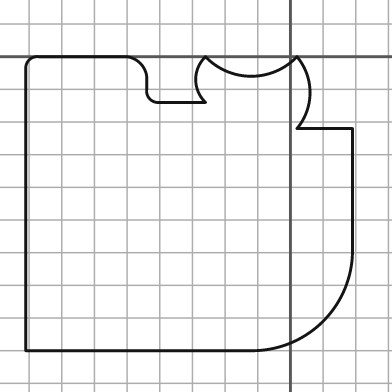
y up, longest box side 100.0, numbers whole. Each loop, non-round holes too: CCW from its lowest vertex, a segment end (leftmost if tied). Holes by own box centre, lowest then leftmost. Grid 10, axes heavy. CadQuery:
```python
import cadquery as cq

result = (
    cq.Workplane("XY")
    .moveTo(-81.0, -90.0)
    .lineTo(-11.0, -90.0)
    .threePointArc((10.0, -81.0), (19.0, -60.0))
    .lineTo(19.0, -22.0)
    .lineTo(2.0, -22.0)
    .threePointArc((6.0, -11.0), (2.0, 0.0))
    .threePointArc((-12.0, -6.0), (-26.0, 0.0))
    .threePointArc((-29.0, -7.0), (-26.0, -14.0))
    .lineTo(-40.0, -14.0)
    .threePointArc((-43.0, -13.0), (-44.0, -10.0))
    .lineTo(-44.0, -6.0)
    .threePointArc((-46.0, -2.0), (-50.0, 0.0))
    .lineTo(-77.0, 0.0)
    .threePointArc((-80.0, -1.0), (-81.0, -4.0))
    .close()
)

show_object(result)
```